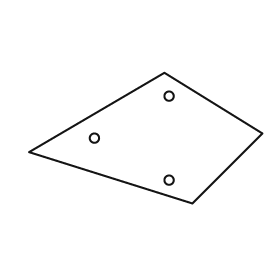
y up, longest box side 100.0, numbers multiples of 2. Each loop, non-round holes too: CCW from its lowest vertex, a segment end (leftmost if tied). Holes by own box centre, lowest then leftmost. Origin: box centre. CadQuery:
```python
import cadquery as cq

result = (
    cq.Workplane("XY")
    .moveTo(20.0, -28.0)
    .lineTo(50.0, 2.0)
    .lineTo(8.0, 28.0)
    .lineTo(-50.0, -6.0)
    .close()
    .moveTo(10.0, -18.0)
    .circle(2.0)
    .moveTo(-22.0, 0.0)
    .circle(2.0)
    .moveTo(10.0, 18.0)
    .circle(2.0)
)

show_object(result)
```